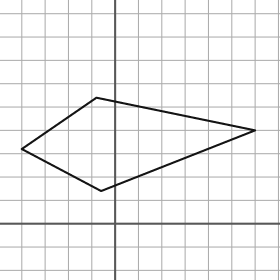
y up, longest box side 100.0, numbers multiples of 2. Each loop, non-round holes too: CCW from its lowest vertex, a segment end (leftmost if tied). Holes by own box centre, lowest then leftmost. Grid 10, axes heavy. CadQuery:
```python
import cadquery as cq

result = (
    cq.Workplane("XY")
    .moveTo(-6.0, 14.0)
    .lineTo(60.0, 40.0)
    .lineTo(-8.0, 54.0)
    .lineTo(-40.0, 32.0)
    .close()
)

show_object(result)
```